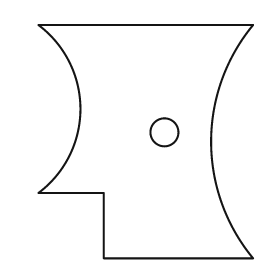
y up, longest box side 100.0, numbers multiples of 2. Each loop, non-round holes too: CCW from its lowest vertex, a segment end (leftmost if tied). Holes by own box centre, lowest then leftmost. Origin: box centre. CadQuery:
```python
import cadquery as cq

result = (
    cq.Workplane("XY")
    .moveTo(-18.0, -50.0)
    .lineTo(46.0, -50.0)
    .threePointArc((28.0, 0.0), (46.0, 50.0))
    .lineTo(-46.0, 50.0)
    .threePointArc((-28.0, 14.0), (-46.0, -22.0))
    .lineTo(-18.0, -22.0)
    .close()
    .moveTo(8.0, 4.0)
    .circle(6.0)
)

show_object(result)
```